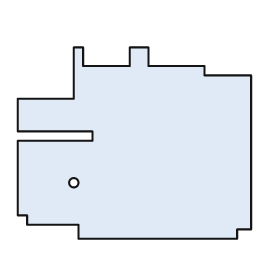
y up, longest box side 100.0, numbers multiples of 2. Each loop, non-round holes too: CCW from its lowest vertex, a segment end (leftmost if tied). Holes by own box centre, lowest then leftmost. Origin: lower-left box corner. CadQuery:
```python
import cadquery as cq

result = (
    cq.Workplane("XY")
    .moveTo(26.0, 0.0)
    .lineTo(94.0, 0.0)
    .lineTo(94.0, 4.0)
    .lineTo(100.0, 4.0)
    .lineTo(100.0, 70.0)
    .lineTo(80.0, 70.0)
    .lineTo(80.0, 74.0)
    .lineTo(56.0, 74.0)
    .lineTo(56.0, 82.0)
    .lineTo(48.0, 82.0)
    .lineTo(48.0, 74.0)
    .lineTo(28.0, 74.0)
    .lineTo(28.0, 82.0)
    .lineTo(24.0, 82.0)
    .lineTo(24.0, 60.0)
    .lineTo(0.0, 60.0)
    .lineTo(0.0, 46.0)
    .lineTo(32.0, 46.0)
    .lineTo(32.0, 42.0)
    .lineTo(0.0, 42.0)
    .lineTo(0.0, 10.0)
    .lineTo(4.0, 10.0)
    .lineTo(4.0, 6.0)
    .lineTo(26.0, 6.0)
    .close()
    .moveTo(24.0, 24.0)
    .circle(2.0)
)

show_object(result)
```